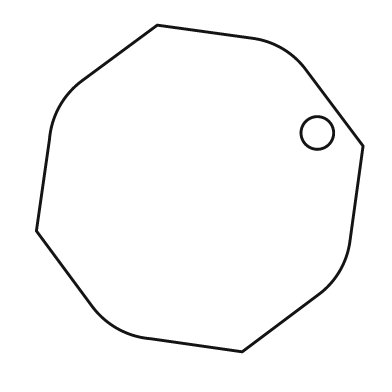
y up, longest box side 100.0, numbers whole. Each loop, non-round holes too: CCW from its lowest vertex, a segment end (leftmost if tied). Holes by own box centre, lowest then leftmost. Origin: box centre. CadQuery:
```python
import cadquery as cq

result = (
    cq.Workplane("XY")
    .moveTo(13.0, -50.0)
    .lineTo(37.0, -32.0)
    .threePointArc((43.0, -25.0), (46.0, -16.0))
    .lineTo(50.0, 13.0)
    .lineTo(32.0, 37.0)
    .threePointArc((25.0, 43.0), (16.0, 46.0))
    .lineTo(-13.0, 50.0)
    .lineTo(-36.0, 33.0)
    .threePointArc((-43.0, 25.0), (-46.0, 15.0))
    .lineTo(-50.0, -13.0)
    .lineTo(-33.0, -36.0)
    .threePointArc((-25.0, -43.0), (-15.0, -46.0))
    .close()
    .moveTo(36.0, 17.0)
    .circle(5.0)
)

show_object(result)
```